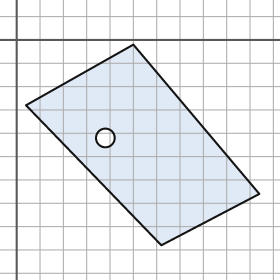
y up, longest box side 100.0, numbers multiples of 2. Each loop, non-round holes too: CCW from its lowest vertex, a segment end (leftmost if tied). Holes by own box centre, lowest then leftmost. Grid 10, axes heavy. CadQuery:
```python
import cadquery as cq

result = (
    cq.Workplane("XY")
    .moveTo(62.0, -88.0)
    .lineTo(104.0, -66.0)
    .lineTo(50.0, -2.0)
    .lineTo(4.0, -28.0)
    .close()
    .moveTo(38.0, -42.0)
    .circle(4.0)
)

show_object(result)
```